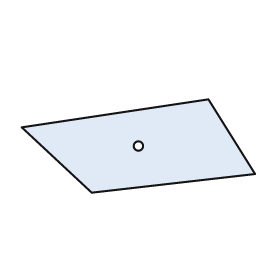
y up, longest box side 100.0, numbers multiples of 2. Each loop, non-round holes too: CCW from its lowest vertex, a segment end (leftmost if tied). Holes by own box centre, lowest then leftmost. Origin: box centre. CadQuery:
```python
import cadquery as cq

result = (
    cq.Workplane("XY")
    .moveTo(-20.0, -20.0)
    .lineTo(50.0, -12.0)
    .lineTo(30.0, 20.0)
    .lineTo(-50.0, 8.0)
    .close()
    .moveTo(0.0, 0.0)
    .circle(2.0)
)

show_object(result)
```